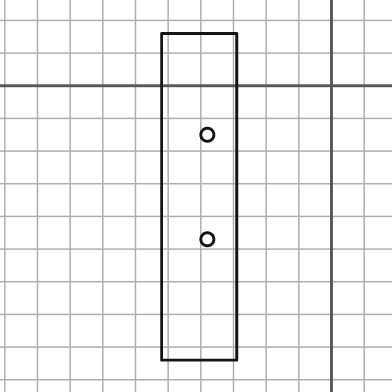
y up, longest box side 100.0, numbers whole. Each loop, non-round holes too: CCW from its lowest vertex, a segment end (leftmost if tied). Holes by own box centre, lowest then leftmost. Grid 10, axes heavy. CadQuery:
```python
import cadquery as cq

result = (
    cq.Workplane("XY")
    .moveTo(-52.0, -84.0)
    .lineTo(-29.0, -84.0)
    .lineTo(-29.0, 16.0)
    .lineTo(-52.0, 16.0)
    .close()
    .moveTo(-38.0, -47.0)
    .circle(2.0)
    .moveTo(-38.0, -15.0)
    .circle(2.0)
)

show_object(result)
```